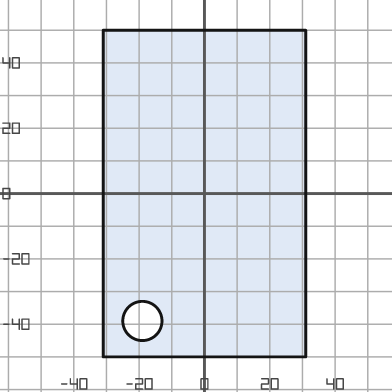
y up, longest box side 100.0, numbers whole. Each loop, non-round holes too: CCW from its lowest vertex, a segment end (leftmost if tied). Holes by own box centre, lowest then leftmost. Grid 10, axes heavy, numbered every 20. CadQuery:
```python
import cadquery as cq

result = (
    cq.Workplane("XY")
    .moveTo(-31.0, -50.0)
    .lineTo(31.0, -50.0)
    .lineTo(31.0, 50.0)
    .lineTo(-31.0, 50.0)
    .close()
    .moveTo(-19.0, -39.0)
    .circle(6.0)
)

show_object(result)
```